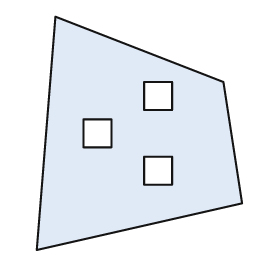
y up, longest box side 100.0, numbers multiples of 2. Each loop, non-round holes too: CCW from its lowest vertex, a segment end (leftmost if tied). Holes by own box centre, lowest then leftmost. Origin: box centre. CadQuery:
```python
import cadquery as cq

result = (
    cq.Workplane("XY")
    .moveTo(-44.0, -50.0)
    .lineTo(44.0, -30.0)
    .lineTo(36.0, 22.0)
    .lineTo(-36.0, 50.0)
    .close()
    .moveTo(2.0, -22.0)
    .lineTo(14.0, -22.0)
    .lineTo(14.0, -10.0)
    .lineTo(2.0, -10.0)
    .close()
    .moveTo(-24.0, -6.0)
    .lineTo(-12.0, -6.0)
    .lineTo(-12.0, 6.0)
    .lineTo(-24.0, 6.0)
    .close()
    .moveTo(2.0, 10.0)
    .lineTo(14.0, 10.0)
    .lineTo(14.0, 22.0)
    .lineTo(2.0, 22.0)
    .close()
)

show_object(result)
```